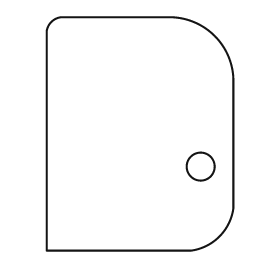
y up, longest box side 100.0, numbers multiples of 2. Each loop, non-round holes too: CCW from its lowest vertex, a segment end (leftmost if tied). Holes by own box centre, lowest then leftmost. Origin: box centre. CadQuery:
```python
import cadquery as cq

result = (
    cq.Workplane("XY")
    .moveTo(-40.0, -50.0)
    .lineTo(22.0, -50.0)
    .threePointArc((34.0, -44.0), (40.0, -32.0))
    .lineTo(40.0, 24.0)
    .threePointArc((32.0, 42.0), (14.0, 50.0))
    .lineTo(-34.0, 50.0)
    .threePointArc((-38.0, 48.0), (-40.0, 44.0))
    .close()
    .moveTo(26.0, -14.0)
    .circle(6.0)
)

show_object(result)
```